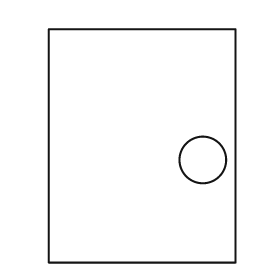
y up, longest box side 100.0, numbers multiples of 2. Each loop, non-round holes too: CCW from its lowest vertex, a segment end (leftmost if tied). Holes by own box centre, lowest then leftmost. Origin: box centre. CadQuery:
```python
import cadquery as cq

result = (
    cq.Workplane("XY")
    .moveTo(-40.0, -50.0)
    .lineTo(40.0, -50.0)
    .lineTo(40.0, 50.0)
    .lineTo(-40.0, 50.0)
    .close()
    .moveTo(26.0, -6.0)
    .circle(10.0)
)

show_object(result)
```